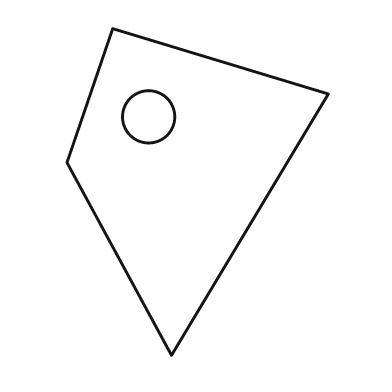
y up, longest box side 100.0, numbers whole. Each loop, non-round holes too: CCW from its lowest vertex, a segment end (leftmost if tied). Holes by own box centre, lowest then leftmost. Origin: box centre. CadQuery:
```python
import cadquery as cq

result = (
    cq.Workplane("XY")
    .moveTo(-8.0, -50.0)
    .lineTo(40.0, 30.0)
    .lineTo(-26.0, 50.0)
    .lineTo(-40.0, 9.0)
    .close()
    .moveTo(-15.0, 23.0)
    .circle(8.0)
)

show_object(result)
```